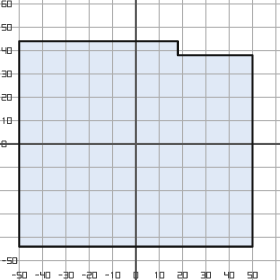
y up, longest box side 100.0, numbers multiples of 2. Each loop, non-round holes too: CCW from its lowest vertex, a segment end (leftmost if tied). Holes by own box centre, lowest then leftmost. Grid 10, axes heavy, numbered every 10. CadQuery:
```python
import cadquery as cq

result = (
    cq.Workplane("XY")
    .moveTo(-50.0, -44.0)
    .lineTo(50.0, -44.0)
    .lineTo(50.0, 38.0)
    .lineTo(18.0, 38.0)
    .lineTo(18.0, 44.0)
    .lineTo(-50.0, 44.0)
    .close()
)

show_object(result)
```